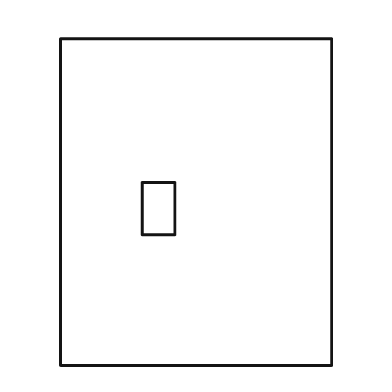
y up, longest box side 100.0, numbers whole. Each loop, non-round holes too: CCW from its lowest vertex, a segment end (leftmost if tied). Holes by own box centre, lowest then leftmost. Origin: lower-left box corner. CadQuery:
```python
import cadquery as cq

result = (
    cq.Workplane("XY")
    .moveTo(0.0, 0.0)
    .lineTo(83.0, 0.0)
    .lineTo(83.0, 100.0)
    .lineTo(0.0, 100.0)
    .close()
    .moveTo(25.0, 40.0)
    .lineTo(35.0, 40.0)
    .lineTo(35.0, 56.0)
    .lineTo(25.0, 56.0)
    .close()
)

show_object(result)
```